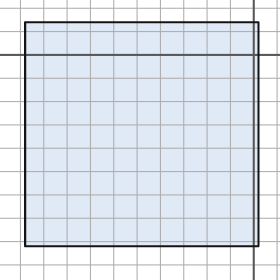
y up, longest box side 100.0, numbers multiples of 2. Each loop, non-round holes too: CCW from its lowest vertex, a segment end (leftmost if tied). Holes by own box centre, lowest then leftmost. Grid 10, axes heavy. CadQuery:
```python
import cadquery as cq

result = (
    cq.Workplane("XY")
    .moveTo(-98.0, -82.0)
    .lineTo(2.0, -82.0)
    .lineTo(2.0, 14.0)
    .lineTo(-98.0, 14.0)
    .close()
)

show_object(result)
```